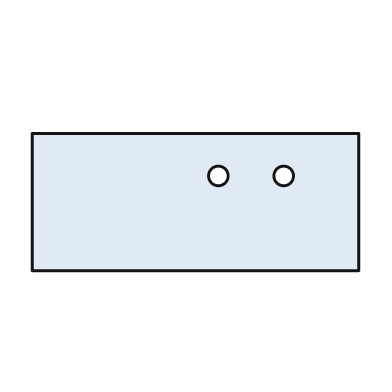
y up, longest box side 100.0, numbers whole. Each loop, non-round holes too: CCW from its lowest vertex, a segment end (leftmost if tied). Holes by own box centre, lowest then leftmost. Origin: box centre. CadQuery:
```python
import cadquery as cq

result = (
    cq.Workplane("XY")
    .moveTo(-50.0, -21.0)
    .lineTo(50.0, -21.0)
    .lineTo(50.0, 21.0)
    .lineTo(-50.0, 21.0)
    .close()
    .moveTo(7.0, 8.0)
    .circle(3.0)
    .moveTo(27.0, 8.0)
    .circle(3.0)
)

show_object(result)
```